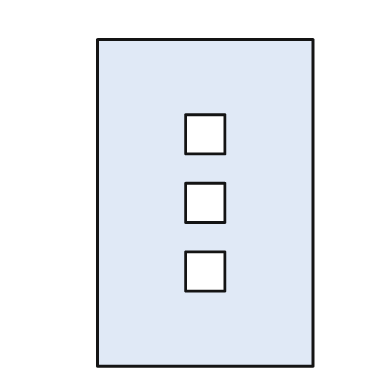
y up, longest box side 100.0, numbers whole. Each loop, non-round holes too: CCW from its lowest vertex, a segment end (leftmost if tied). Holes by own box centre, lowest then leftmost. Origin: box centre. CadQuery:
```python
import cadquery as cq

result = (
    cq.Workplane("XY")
    .moveTo(-33.0, -50.0)
    .lineTo(33.0, -50.0)
    .lineTo(33.0, 50.0)
    .lineTo(-33.0, 50.0)
    .close()
    .moveTo(-6.0, -27.0)
    .lineTo(6.0, -27.0)
    .lineTo(6.0, -15.0)
    .lineTo(-6.0, -15.0)
    .close()
    .moveTo(-6.0, -6.0)
    .lineTo(6.0, -6.0)
    .lineTo(6.0, 6.0)
    .lineTo(-6.0, 6.0)
    .close()
    .moveTo(-6.0, 15.0)
    .lineTo(6.0, 15.0)
    .lineTo(6.0, 27.0)
    .lineTo(-6.0, 27.0)
    .close()
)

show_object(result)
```